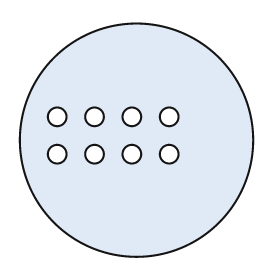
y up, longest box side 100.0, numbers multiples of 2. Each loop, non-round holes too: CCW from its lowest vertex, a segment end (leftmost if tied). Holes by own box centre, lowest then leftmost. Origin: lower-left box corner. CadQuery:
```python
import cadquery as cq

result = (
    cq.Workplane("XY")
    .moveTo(50.0, 50.0)
    .circle(50.0)
    .moveTo(16.0, 44.0)
    .circle(4.0)
    .moveTo(32.0, 44.0)
    .circle(4.0)
    .moveTo(48.0, 44.0)
    .circle(4.0)
    .moveTo(64.0, 44.0)
    .circle(4.0)
    .moveTo(16.0, 60.0)
    .circle(4.0)
    .moveTo(32.0, 60.0)
    .circle(4.0)
    .moveTo(48.0, 60.0)
    .circle(4.0)
    .moveTo(64.0, 60.0)
    .circle(4.0)
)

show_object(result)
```